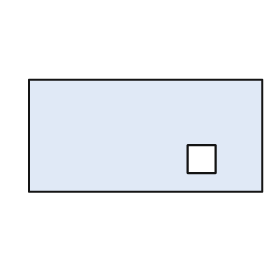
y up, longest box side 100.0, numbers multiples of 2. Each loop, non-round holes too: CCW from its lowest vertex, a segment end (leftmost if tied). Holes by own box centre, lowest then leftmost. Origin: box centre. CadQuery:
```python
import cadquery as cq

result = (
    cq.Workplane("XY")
    .moveTo(-50.0, -24.0)
    .lineTo(50.0, -24.0)
    .lineTo(50.0, 24.0)
    .lineTo(-50.0, 24.0)
    .close()
    .moveTo(18.0, -16.0)
    .lineTo(30.0, -16.0)
    .lineTo(30.0, -4.0)
    .lineTo(18.0, -4.0)
    .close()
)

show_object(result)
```